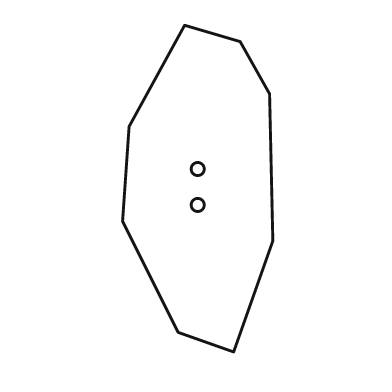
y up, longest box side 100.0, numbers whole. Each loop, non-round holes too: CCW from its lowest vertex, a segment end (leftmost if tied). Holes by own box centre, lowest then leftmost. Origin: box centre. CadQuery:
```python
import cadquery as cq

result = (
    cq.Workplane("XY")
    .moveTo(11.0, -50.0)
    .lineTo(23.0, -16.0)
    .lineTo(22.0, 29.0)
    .lineTo(13.0, 45.0)
    .lineTo(-4.0, 50.0)
    .lineTo(-21.0, 19.0)
    .lineTo(-23.0, -10.0)
    .lineTo(-6.0, -44.0)
    .close()
    .moveTo(0.0, -5.0)
    .circle(2.0)
    .moveTo(0.0, 6.0)
    .circle(2.0)
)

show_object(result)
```